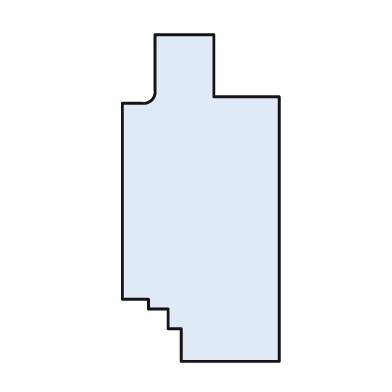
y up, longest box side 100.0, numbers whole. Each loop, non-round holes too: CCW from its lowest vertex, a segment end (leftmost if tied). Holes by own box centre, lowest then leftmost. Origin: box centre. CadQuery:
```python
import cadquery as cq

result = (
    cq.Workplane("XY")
    .moveTo(-6.0, -50.0)
    .lineTo(24.0, -50.0)
    .lineTo(24.0, 31.0)
    .lineTo(4.0, 31.0)
    .lineTo(4.0, 50.0)
    .lineTo(-14.0, 50.0)
    .lineTo(-14.0, 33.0)
    .threePointArc((-15.0, 30.0), (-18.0, 29.0))
    .lineTo(-24.0, 29.0)
    .lineTo(-24.0, -31.0)
    .lineTo(-16.0, -31.0)
    .lineTo(-16.0, -34.0)
    .lineTo(-10.0, -34.0)
    .lineTo(-10.0, -40.0)
    .lineTo(-6.0, -40.0)
    .close()
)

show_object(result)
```